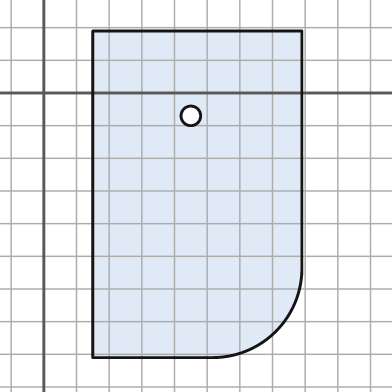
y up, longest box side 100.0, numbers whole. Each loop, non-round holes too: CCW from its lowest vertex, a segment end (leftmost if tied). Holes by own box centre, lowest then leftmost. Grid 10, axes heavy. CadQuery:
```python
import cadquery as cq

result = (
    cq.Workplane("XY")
    .moveTo(15.0, -81.0)
    .lineTo(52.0, -81.0)
    .threePointArc((71.0, -73.0), (79.0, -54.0))
    .lineTo(79.0, 19.0)
    .lineTo(15.0, 19.0)
    .close()
    .moveTo(45.0, -7.0)
    .circle(3.0)
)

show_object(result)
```